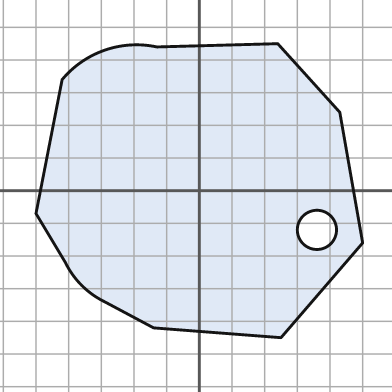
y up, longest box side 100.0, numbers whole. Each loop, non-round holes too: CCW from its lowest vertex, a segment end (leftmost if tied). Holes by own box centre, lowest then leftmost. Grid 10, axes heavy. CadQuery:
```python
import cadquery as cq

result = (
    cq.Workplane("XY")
    .moveTo(25.0, -45.0)
    .lineTo(50.0, -16.0)
    .lineTo(43.0, 24.0)
    .lineTo(24.0, 45.0)
    .lineTo(-13.0, 44.0)
    .threePointArc((-29.0, 43.0), (-42.0, 34.0))
    .lineTo(-50.0, -7.0)
    .lineTo(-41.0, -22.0)
    .threePointArc((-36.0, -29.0), (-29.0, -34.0))
    .lineTo(-14.0, -42.0)
    .close()
    .moveTo(36.0, -12.0)
    .circle(6.0)
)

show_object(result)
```